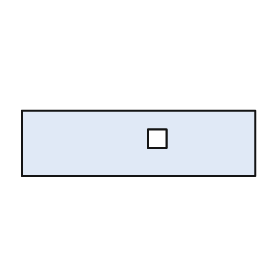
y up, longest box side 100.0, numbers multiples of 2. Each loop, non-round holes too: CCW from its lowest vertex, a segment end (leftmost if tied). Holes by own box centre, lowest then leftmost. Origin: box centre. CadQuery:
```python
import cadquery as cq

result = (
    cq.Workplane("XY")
    .moveTo(-50.0, -14.0)
    .lineTo(50.0, -14.0)
    .lineTo(50.0, 14.0)
    .lineTo(-50.0, 14.0)
    .close()
    .moveTo(4.0, -2.0)
    .lineTo(12.0, -2.0)
    .lineTo(12.0, 6.0)
    .lineTo(4.0, 6.0)
    .close()
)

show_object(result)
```